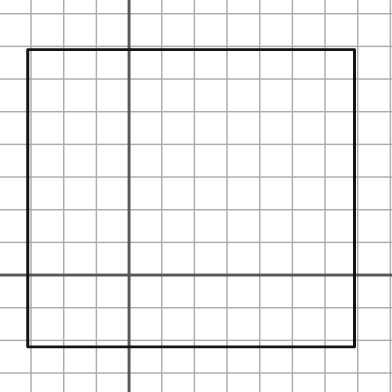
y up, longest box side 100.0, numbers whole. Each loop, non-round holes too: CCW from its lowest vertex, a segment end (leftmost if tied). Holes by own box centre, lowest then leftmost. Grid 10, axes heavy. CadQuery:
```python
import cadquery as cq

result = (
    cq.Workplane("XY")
    .moveTo(-31.0, -22.0)
    .lineTo(69.0, -22.0)
    .lineTo(69.0, 69.0)
    .lineTo(-31.0, 69.0)
    .close()
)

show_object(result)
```